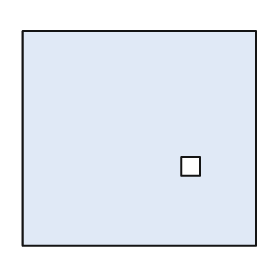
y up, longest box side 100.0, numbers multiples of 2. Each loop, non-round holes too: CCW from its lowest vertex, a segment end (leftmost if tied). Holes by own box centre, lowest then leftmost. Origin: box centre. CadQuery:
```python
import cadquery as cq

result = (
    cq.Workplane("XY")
    .moveTo(-50.0, -46.0)
    .lineTo(50.0, -46.0)
    .lineTo(50.0, 46.0)
    .lineTo(-50.0, 46.0)
    .close()
    .moveTo(18.0, -16.0)
    .lineTo(26.0, -16.0)
    .lineTo(26.0, -8.0)
    .lineTo(18.0, -8.0)
    .close()
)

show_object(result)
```